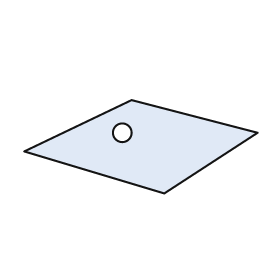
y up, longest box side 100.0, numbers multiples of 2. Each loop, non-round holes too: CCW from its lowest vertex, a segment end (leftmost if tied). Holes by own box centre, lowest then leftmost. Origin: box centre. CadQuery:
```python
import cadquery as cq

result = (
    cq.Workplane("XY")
    .moveTo(10.0, -20.0)
    .lineTo(50.0, 6.0)
    .lineTo(-4.0, 20.0)
    .lineTo(-50.0, -2.0)
    .close()
    .moveTo(-8.0, 6.0)
    .circle(4.0)
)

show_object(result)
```